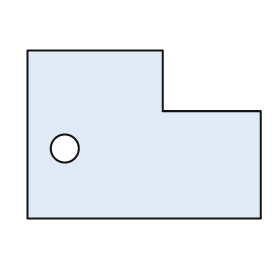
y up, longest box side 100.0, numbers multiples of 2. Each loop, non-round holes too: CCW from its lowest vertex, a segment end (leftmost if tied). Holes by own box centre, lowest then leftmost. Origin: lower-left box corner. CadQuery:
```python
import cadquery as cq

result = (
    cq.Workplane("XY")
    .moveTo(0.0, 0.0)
    .lineTo(100.0, 0.0)
    .lineTo(100.0, 46.0)
    .lineTo(58.0, 46.0)
    .lineTo(58.0, 72.0)
    .lineTo(0.0, 72.0)
    .close()
    .moveTo(16.0, 30.0)
    .circle(6.0)
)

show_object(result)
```